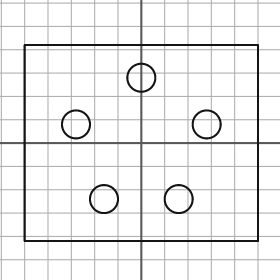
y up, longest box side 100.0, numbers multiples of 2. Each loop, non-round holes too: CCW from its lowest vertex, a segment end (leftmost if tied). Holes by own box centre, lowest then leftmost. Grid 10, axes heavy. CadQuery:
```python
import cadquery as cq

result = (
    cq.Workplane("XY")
    .moveTo(-50.0, -42.0)
    .lineTo(50.0, -42.0)
    .lineTo(50.0, 42.0)
    .lineTo(-50.0, 42.0)
    .close()
    .moveTo(-16.0, -24.0)
    .circle(6.0)
    .moveTo(16.0, -24.0)
    .circle(6.0)
    .moveTo(-28.0, 8.0)
    .circle(6.0)
    .moveTo(28.0, 8.0)
    .circle(6.0)
    .moveTo(0.0, 28.0)
    .circle(6.0)
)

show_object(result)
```